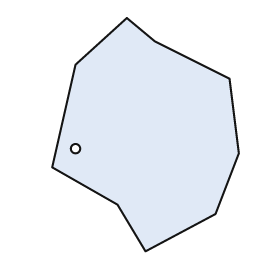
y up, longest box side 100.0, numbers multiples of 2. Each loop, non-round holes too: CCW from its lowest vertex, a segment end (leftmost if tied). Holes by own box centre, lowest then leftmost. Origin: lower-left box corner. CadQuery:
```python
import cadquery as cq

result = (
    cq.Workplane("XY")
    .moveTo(40.0, 0.0)
    .lineTo(70.0, 16.0)
    .lineTo(80.0, 42.0)
    .lineTo(76.0, 74.0)
    .lineTo(44.0, 90.0)
    .lineTo(32.0, 100.0)
    .lineTo(10.0, 80.0)
    .lineTo(0.0, 36.0)
    .lineTo(28.0, 20.0)
    .close()
    .moveTo(10.0, 44.0)
    .circle(2.0)
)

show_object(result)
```